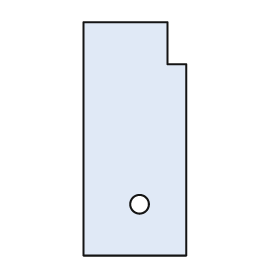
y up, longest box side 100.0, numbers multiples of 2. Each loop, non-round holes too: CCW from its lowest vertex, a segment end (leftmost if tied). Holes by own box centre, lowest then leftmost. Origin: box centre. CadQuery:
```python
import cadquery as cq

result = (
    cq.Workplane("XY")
    .moveTo(-22.0, -50.0)
    .lineTo(22.0, -50.0)
    .lineTo(22.0, 32.0)
    .lineTo(14.0, 32.0)
    .lineTo(14.0, 50.0)
    .lineTo(-22.0, 50.0)
    .close()
    .moveTo(2.0, -28.0)
    .circle(4.0)
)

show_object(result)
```